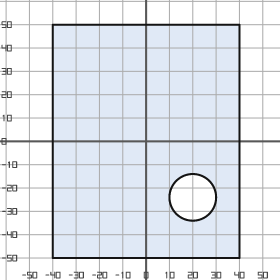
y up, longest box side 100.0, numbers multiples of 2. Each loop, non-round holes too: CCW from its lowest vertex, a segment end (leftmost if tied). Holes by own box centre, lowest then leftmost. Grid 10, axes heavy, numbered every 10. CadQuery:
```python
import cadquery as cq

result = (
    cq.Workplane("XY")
    .moveTo(-40.0, -50.0)
    .lineTo(40.0, -50.0)
    .lineTo(40.0, 50.0)
    .lineTo(-40.0, 50.0)
    .close()
    .moveTo(20.0, -24.0)
    .circle(10.0)
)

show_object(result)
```